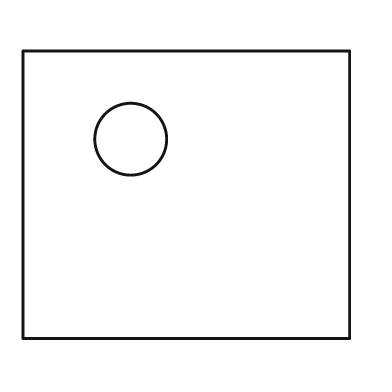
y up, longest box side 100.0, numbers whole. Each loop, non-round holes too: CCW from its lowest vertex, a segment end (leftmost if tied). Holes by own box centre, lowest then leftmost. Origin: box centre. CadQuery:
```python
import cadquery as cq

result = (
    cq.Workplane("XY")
    .moveTo(-50.0, -44.0)
    .lineTo(50.0, -44.0)
    .lineTo(50.0, 44.0)
    .lineTo(-50.0, 44.0)
    .close()
    .moveTo(-17.0, 17.0)
    .circle(11.0)
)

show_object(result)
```